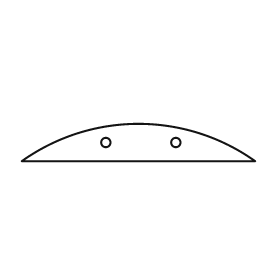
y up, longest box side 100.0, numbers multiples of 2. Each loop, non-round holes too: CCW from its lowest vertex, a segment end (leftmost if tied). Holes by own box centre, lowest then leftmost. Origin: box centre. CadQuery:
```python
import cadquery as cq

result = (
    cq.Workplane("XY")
    .moveTo(-50.0, -8.0)
    .lineTo(50.0, -8.0)
    .threePointArc((0.0, 8.0), (-50.0, -8.0))
    .close()
    .moveTo(-14.0, 0.0)
    .circle(2.0)
    .moveTo(16.0, 0.0)
    .circle(2.0)
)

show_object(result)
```